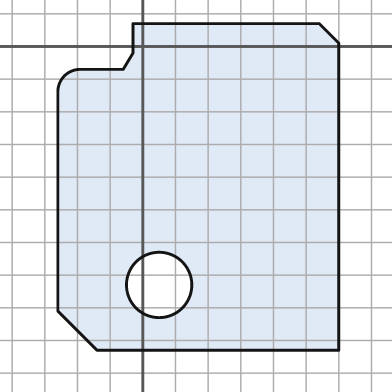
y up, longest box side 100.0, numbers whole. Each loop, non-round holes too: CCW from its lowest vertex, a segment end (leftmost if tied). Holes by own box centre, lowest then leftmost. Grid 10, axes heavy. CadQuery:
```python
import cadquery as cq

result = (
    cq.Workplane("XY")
    .moveTo(-14.0, -93.0)
    .lineTo(60.0, -93.0)
    .lineTo(60.0, 1.0)
    .lineTo(54.0, 7.0)
    .lineTo(-3.0, 7.0)
    .lineTo(-3.0, -2.0)
    .lineTo(-6.0, -7.0)
    .lineTo(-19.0, -7.0)
    .threePointArc((-24.0, -9.0), (-26.0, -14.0))
    .lineTo(-26.0, -81.0)
    .close()
    .moveTo(5.0, -73.0)
    .circle(10.0)
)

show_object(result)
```